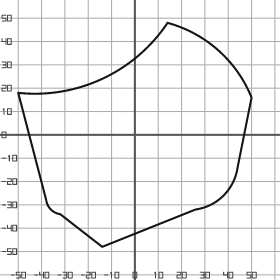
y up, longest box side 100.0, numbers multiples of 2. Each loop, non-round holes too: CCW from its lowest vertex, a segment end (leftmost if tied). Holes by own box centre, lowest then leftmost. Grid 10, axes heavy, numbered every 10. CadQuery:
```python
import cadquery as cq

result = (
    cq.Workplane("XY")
    .moveTo(-14.0, -48.0)
    .lineTo(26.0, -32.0)
    .threePointArc((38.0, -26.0), (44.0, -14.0))
    .lineTo(50.0, 16.0)
    .threePointArc((36.0, 36.0), (14.0, 48.0))
    .threePointArc((-14.0, 24.0), (-50.0, 18.0))
    .lineTo(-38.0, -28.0)
    .threePointArc((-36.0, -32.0), (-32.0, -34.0))
    .close()
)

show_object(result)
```